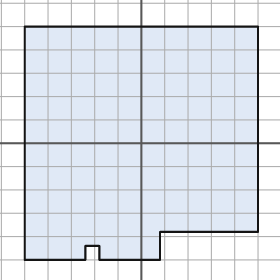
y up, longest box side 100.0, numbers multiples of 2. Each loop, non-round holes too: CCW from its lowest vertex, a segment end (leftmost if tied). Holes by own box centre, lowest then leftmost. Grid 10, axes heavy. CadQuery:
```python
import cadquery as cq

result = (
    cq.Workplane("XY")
    .moveTo(-50.0, -50.0)
    .lineTo(-24.0, -50.0)
    .lineTo(-24.0, -44.0)
    .lineTo(-18.0, -44.0)
    .lineTo(-18.0, -50.0)
    .lineTo(8.0, -50.0)
    .lineTo(8.0, -38.0)
    .lineTo(50.0, -38.0)
    .lineTo(50.0, 50.0)
    .lineTo(-50.0, 50.0)
    .close()
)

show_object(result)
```